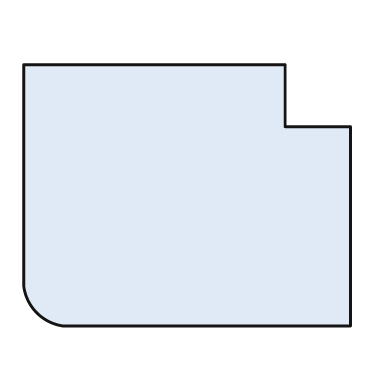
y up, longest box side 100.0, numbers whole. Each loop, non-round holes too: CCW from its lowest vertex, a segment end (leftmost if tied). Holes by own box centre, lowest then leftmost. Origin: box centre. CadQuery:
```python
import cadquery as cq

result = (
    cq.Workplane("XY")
    .moveTo(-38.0, -40.0)
    .lineTo(50.0, -40.0)
    .lineTo(50.0, 21.0)
    .lineTo(30.0, 21.0)
    .lineTo(30.0, 40.0)
    .lineTo(-50.0, 40.0)
    .lineTo(-50.0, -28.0)
    .threePointArc((-46.0, -36.0), (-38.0, -40.0))
    .close()
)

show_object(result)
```